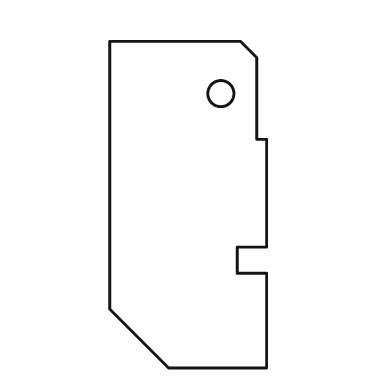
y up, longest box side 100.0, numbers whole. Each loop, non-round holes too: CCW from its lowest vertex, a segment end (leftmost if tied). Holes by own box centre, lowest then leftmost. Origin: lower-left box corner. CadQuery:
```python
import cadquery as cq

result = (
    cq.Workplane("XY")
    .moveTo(18.0, 0.0)
    .lineTo(48.0, 0.0)
    .lineTo(48.0, 29.0)
    .lineTo(39.0, 29.0)
    .lineTo(39.0, 37.0)
    .lineTo(48.0, 37.0)
    .lineTo(48.0, 70.0)
    .lineTo(45.0, 70.0)
    .lineTo(45.0, 95.0)
    .lineTo(40.0, 100.0)
    .lineTo(0.0, 100.0)
    .lineTo(0.0, 18.0)
    .close()
    .moveTo(34.0, 84.0)
    .circle(4.0)
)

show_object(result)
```